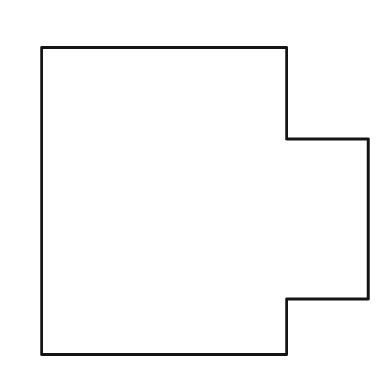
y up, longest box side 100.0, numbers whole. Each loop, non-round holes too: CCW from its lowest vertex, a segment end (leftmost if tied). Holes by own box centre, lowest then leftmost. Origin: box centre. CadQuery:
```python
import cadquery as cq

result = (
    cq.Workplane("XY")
    .moveTo(-50.0, -47.0)
    .lineTo(25.0, -47.0)
    .lineTo(25.0, -30.0)
    .lineTo(50.0, -30.0)
    .lineTo(50.0, 19.0)
    .lineTo(25.0, 19.0)
    .lineTo(25.0, 47.0)
    .lineTo(-50.0, 47.0)
    .close()
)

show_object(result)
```